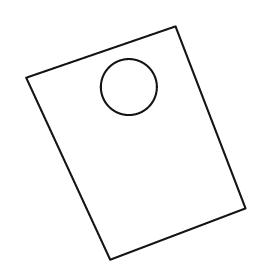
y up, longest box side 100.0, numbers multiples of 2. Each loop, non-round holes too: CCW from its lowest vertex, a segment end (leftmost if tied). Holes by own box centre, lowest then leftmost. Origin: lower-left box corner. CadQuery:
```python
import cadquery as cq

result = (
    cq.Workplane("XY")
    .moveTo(36.0, 0.0)
    .lineTo(94.0, 22.0)
    .lineTo(64.0, 100.0)
    .lineTo(0.0, 78.0)
    .close()
    .moveTo(44.0, 74.0)
    .circle(12.0)
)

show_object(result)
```